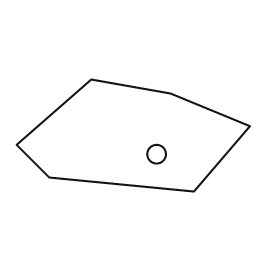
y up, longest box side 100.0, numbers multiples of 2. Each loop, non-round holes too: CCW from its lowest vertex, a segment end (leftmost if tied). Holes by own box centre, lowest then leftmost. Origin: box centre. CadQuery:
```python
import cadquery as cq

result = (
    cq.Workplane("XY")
    .moveTo(26.0, -24.0)
    .lineTo(50.0, 4.0)
    .lineTo(16.0, 18.0)
    .lineTo(-18.0, 24.0)
    .lineTo(-50.0, -4.0)
    .lineTo(-36.0, -18.0)
    .close()
    .moveTo(10.0, -8.0)
    .circle(4.0)
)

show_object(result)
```